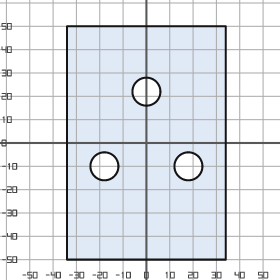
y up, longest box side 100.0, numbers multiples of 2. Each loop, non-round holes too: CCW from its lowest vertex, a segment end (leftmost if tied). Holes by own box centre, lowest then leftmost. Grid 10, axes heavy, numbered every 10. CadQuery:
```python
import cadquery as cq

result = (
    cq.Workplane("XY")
    .moveTo(-34.0, -50.0)
    .lineTo(34.0, -50.0)
    .lineTo(34.0, 50.0)
    .lineTo(-34.0, 50.0)
    .close()
    .moveTo(-18.0, -10.0)
    .circle(6.0)
    .moveTo(18.0, -10.0)
    .circle(6.0)
    .moveTo(0.0, 22.0)
    .circle(6.0)
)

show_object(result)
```